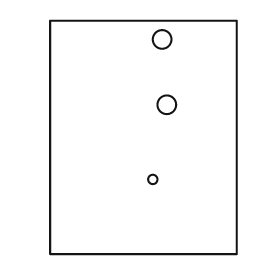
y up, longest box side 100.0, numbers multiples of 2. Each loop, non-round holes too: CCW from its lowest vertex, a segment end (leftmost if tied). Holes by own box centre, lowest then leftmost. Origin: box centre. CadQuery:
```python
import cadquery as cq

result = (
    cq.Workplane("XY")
    .moveTo(-40.0, -50.0)
    .lineTo(40.0, -50.0)
    .lineTo(40.0, 50.0)
    .lineTo(-40.0, 50.0)
    .close()
    .moveTo(4.0, -18.0)
    .circle(2.0)
    .moveTo(10.0, 14.0)
    .circle(4.0)
    .moveTo(8.0, 42.0)
    .circle(4.0)
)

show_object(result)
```